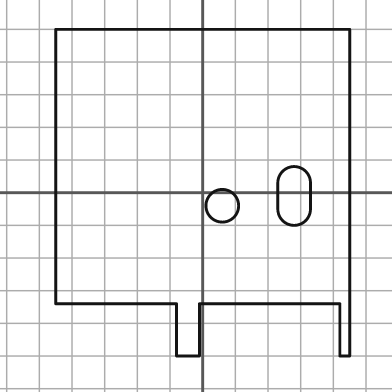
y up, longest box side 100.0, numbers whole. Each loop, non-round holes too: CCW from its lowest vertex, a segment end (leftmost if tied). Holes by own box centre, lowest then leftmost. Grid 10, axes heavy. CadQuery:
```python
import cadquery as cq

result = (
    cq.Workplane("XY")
    .moveTo(-8.0, -50.0)
    .lineTo(-1.0, -50.0)
    .lineTo(-1.0, -34.0)
    .lineTo(42.0, -34.0)
    .lineTo(42.0, -50.0)
    .lineTo(45.0, -50.0)
    .lineTo(45.0, 50.0)
    .lineTo(-45.0, 50.0)
    .lineTo(-45.0, -34.0)
    .lineTo(-8.0, -34.0)
    .close()
    .moveTo(6.0, -4.0)
    .circle(5.0)
    .moveTo(23.0, -5.0)
    .threePointArc((28.0, -10.0), (33.0, -5.0))
    .lineTo(33.0, 3.0)
    .threePointArc((28.0, 8.0), (23.0, 3.0))
    .close()
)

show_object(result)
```